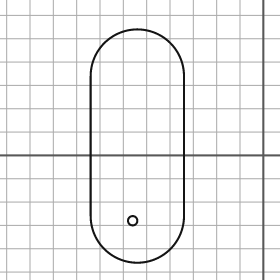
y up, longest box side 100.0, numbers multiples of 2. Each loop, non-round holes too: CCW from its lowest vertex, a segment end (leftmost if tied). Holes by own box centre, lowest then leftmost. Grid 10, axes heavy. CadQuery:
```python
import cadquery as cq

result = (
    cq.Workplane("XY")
    .moveTo(-74.0, -26.0)
    .threePointArc((-54.0, -46.0), (-34.0, -26.0))
    .lineTo(-34.0, 34.0)
    .threePointArc((-54.0, 54.0), (-74.0, 34.0))
    .close()
    .moveTo(-56.0, -28.0)
    .circle(2.0)
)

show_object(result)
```